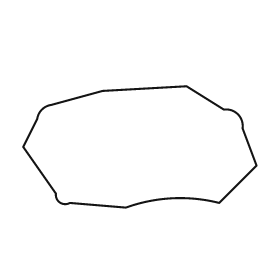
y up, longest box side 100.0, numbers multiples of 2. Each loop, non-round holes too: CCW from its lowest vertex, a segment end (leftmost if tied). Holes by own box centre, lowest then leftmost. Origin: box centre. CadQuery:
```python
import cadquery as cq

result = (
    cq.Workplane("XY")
    .moveTo(-6.0, -26.0)
    .threePointArc((14.0, -22.0), (34.0, -24.0))
    .lineTo(50.0, -8.0)
    .lineTo(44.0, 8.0)
    .threePointArc((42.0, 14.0), (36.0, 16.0))
    .lineTo(20.0, 26.0)
    .lineTo(-16.0, 24.0)
    .lineTo(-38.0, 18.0)
    .threePointArc((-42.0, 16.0), (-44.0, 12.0))
    .lineTo(-50.0, 0.0)
    .lineTo(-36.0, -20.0)
    .threePointArc((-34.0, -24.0), (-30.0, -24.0))
    .close()
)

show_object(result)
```